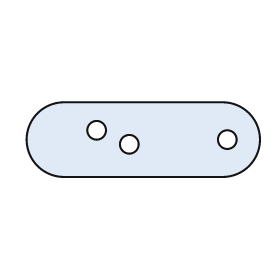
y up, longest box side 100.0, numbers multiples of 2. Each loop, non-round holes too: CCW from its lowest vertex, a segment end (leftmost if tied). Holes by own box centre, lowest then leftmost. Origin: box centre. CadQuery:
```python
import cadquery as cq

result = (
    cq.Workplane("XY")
    .moveTo(-34.0, -16.0)
    .lineTo(34.0, -16.0)
    .threePointArc((50.0, 0.0), (34.0, 16.0))
    .lineTo(-34.0, 16.0)
    .threePointArc((-50.0, 0.0), (-34.0, -16.0))
    .close()
    .moveTo(-6.0, -2.0)
    .circle(4.0)
    .moveTo(36.0, 0.0)
    .circle(4.0)
    .moveTo(-20.0, 4.0)
    .circle(4.0)
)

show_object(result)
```